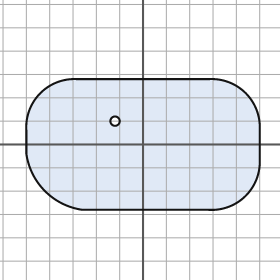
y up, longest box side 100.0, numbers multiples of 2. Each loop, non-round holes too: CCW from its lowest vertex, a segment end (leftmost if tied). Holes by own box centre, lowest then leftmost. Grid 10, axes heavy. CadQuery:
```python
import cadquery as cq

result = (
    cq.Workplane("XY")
    .moveTo(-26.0, -28.0)
    .lineTo(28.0, -28.0)
    .threePointArc((44.0, -22.0), (50.0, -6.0))
    .lineTo(50.0, 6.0)
    .threePointArc((44.0, 22.0), (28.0, 28.0))
    .lineTo(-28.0, 28.0)
    .threePointArc((-44.0, 22.0), (-50.0, 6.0))
    .lineTo(-50.0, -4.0)
    .threePointArc((-42.0, -20.0), (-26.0, -28.0))
    .close()
    .moveTo(-12.0, 10.0)
    .circle(2.0)
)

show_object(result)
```